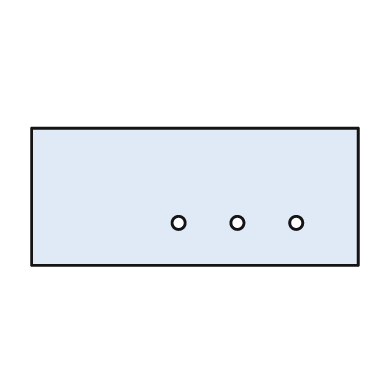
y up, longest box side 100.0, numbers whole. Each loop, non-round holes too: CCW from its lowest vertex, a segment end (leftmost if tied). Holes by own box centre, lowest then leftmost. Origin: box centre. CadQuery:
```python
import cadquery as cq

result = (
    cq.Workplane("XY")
    .moveTo(-50.0, -21.0)
    .lineTo(50.0, -21.0)
    .lineTo(50.0, 21.0)
    .lineTo(-50.0, 21.0)
    .close()
    .moveTo(-5.0, -8.0)
    .circle(2.0)
    .moveTo(13.0, -8.0)
    .circle(2.0)
    .moveTo(31.0, -8.0)
    .circle(2.0)
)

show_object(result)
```